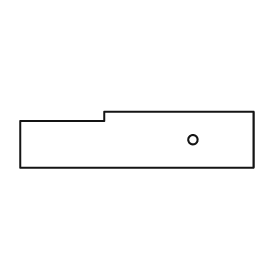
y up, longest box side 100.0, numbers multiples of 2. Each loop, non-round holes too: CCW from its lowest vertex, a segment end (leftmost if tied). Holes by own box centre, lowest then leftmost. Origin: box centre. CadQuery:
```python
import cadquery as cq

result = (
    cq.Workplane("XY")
    .moveTo(-50.0, -12.0)
    .lineTo(50.0, -12.0)
    .lineTo(50.0, 12.0)
    .lineTo(-14.0, 12.0)
    .lineTo(-14.0, 8.0)
    .lineTo(-50.0, 8.0)
    .close()
    .moveTo(24.0, 0.0)
    .circle(2.0)
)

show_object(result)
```